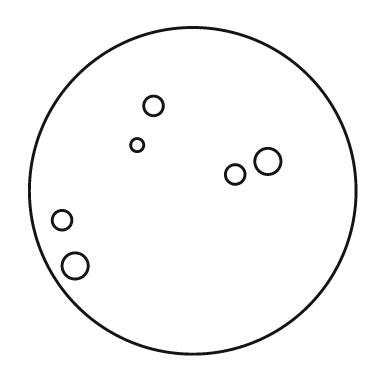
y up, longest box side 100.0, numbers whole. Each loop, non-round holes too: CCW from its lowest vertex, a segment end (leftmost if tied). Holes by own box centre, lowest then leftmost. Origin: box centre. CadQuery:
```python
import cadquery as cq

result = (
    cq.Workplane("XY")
    .moveTo(0.0, 0.0)
    .circle(50.0)
    .moveTo(-36.0, -23.0)
    .circle(4.0)
    .moveTo(-40.0, -9.0)
    .circle(3.0)
    .moveTo(13.0, 5.0)
    .circle(3.0)
    .moveTo(23.0, 9.0)
    .circle(4.0)
    .moveTo(-17.0, 14.0)
    .circle(2.0)
    .moveTo(-12.0, 26.0)
    .circle(3.0)
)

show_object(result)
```